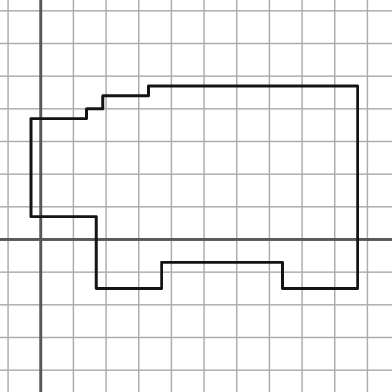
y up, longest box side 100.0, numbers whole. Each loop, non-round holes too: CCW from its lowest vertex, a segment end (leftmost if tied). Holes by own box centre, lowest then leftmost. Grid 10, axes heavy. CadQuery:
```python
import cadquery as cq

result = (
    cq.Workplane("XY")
    .moveTo(17.0, -15.0)
    .lineTo(37.0, -15.0)
    .lineTo(37.0, -7.0)
    .lineTo(74.0, -7.0)
    .lineTo(74.0, -15.0)
    .lineTo(97.0, -15.0)
    .lineTo(97.0, 47.0)
    .lineTo(33.0, 47.0)
    .lineTo(33.0, 44.0)
    .lineTo(19.0, 44.0)
    .lineTo(19.0, 40.0)
    .lineTo(14.0, 40.0)
    .lineTo(14.0, 37.0)
    .lineTo(-3.0, 37.0)
    .lineTo(-3.0, 7.0)
    .lineTo(17.0, 7.0)
    .close()
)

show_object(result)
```